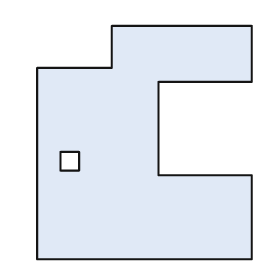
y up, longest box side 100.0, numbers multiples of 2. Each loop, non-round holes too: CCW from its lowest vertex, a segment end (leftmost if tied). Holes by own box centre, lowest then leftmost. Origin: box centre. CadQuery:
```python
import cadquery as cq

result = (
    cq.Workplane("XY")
    .moveTo(-46.0, -50.0)
    .lineTo(46.0, -50.0)
    .lineTo(46.0, -14.0)
    .lineTo(6.0, -14.0)
    .lineTo(6.0, 26.0)
    .lineTo(46.0, 26.0)
    .lineTo(46.0, 50.0)
    .lineTo(-14.0, 50.0)
    .lineTo(-14.0, 32.0)
    .lineTo(-46.0, 32.0)
    .close()
    .moveTo(-36.0, -12.0)
    .lineTo(-28.0, -12.0)
    .lineTo(-28.0, -4.0)
    .lineTo(-36.0, -4.0)
    .close()
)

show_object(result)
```